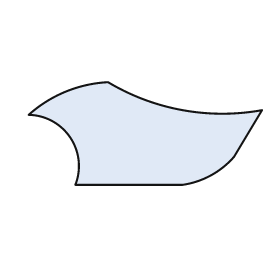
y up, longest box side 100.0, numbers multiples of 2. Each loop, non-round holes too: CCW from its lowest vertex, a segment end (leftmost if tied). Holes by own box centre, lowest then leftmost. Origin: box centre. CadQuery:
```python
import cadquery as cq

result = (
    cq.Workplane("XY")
    .moveTo(-30.0, -22.0)
    .lineTo(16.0, -22.0)
    .threePointArc((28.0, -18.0), (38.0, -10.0))
    .lineTo(50.0, 10.0)
    .threePointArc((16.0, 10.0), (-16.0, 22.0))
    .threePointArc((-34.0, 18.0), (-50.0, 8.0))
    .threePointArc((-32.0, -2.0), (-30.0, -22.0))
    .close()
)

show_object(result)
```